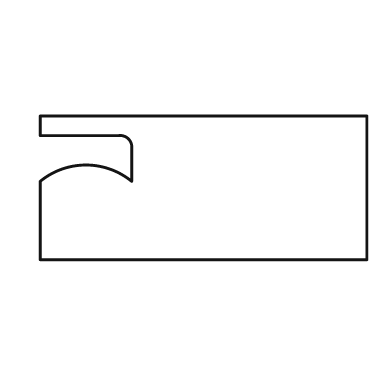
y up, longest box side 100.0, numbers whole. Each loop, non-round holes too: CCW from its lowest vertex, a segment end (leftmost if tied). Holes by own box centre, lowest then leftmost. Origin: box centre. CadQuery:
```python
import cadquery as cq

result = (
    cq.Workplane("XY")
    .moveTo(-50.0, -22.0)
    .lineTo(50.0, -22.0)
    .lineTo(50.0, 22.0)
    .lineTo(-50.0, 22.0)
    .lineTo(-50.0, 16.0)
    .lineTo(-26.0, 16.0)
    .threePointArc((-23.0, 15.0), (-22.0, 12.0))
    .lineTo(-22.0, 2.0)
    .threePointArc((-36.0, 7.0), (-50.0, 2.0))
    .close()
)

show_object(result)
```